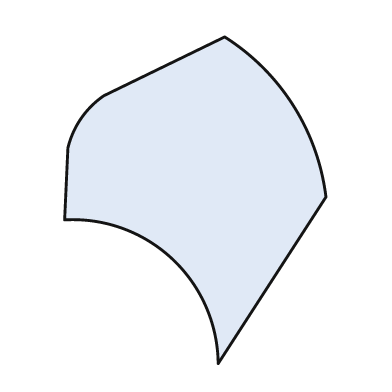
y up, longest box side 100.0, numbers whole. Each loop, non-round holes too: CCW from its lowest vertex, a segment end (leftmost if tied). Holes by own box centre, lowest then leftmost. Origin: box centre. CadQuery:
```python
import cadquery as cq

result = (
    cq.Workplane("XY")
    .moveTo(7.0, -50.0)
    .lineTo(40.0, 1.0)
    .threePointArc((30.0, 29.0), (9.0, 50.0))
    .lineTo(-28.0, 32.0)
    .threePointArc((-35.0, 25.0), (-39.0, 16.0))
    .lineTo(-40.0, -6.0)
    .threePointArc((-7.0, -18.0), (7.0, -50.0))
    .close()
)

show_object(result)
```